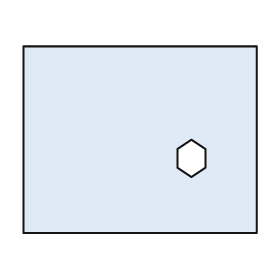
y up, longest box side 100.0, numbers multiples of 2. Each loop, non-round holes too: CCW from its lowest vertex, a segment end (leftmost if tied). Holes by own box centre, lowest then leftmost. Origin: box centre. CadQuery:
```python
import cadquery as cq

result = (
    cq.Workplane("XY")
    .moveTo(-50.0, -40.0)
    .lineTo(50.0, -40.0)
    .lineTo(50.0, 40.0)
    .lineTo(-50.0, 40.0)
    .close()
    .moveTo(22.0, -16.0)
    .lineTo(28.0, -12.0)
    .lineTo(28.0, -4.0)
    .lineTo(22.0, 0.0)
    .lineTo(16.0, -4.0)
    .lineTo(16.0, -12.0)
    .close()
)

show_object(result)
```